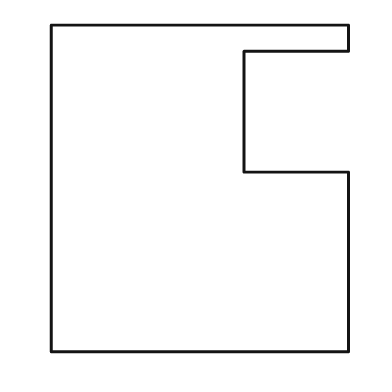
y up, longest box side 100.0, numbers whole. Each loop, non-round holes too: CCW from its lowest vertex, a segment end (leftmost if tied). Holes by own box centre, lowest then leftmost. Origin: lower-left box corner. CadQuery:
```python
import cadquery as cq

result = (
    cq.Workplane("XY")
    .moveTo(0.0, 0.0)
    .lineTo(91.0, 0.0)
    .lineTo(91.0, 55.0)
    .lineTo(59.0, 55.0)
    .lineTo(59.0, 92.0)
    .lineTo(91.0, 92.0)
    .lineTo(91.0, 100.0)
    .lineTo(0.0, 100.0)
    .close()
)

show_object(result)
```